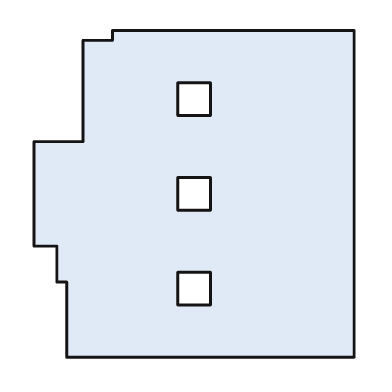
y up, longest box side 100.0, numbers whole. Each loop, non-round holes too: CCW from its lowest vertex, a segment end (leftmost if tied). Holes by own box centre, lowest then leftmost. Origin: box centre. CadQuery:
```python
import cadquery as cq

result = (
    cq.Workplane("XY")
    .moveTo(-39.0, -50.0)
    .lineTo(49.0, -50.0)
    .lineTo(49.0, 50.0)
    .lineTo(-25.0, 50.0)
    .lineTo(-25.0, 47.0)
    .lineTo(-34.0, 47.0)
    .lineTo(-34.0, 16.0)
    .lineTo(-49.0, 16.0)
    .lineTo(-49.0, -16.0)
    .lineTo(-42.0, -16.0)
    .lineTo(-42.0, -27.0)
    .lineTo(-39.0, -27.0)
    .close()
    .moveTo(-5.0, -34.0)
    .lineTo(5.0, -34.0)
    .lineTo(5.0, -24.0)
    .lineTo(-5.0, -24.0)
    .close()
    .moveTo(-5.0, -5.0)
    .lineTo(5.0, -5.0)
    .lineTo(5.0, 5.0)
    .lineTo(-5.0, 5.0)
    .close()
    .moveTo(-5.0, 24.0)
    .lineTo(5.0, 24.0)
    .lineTo(5.0, 34.0)
    .lineTo(-5.0, 34.0)
    .close()
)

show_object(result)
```